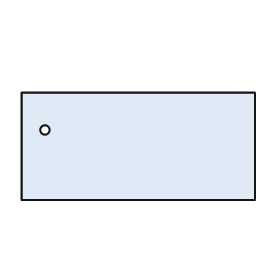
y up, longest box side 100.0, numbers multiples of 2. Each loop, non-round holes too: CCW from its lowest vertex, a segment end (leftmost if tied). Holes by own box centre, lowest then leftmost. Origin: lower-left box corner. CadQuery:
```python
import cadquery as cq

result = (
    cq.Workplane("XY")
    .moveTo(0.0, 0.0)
    .lineTo(100.0, 0.0)
    .lineTo(100.0, 46.0)
    .lineTo(0.0, 46.0)
    .close()
    .moveTo(10.0, 30.0)
    .circle(2.0)
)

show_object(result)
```